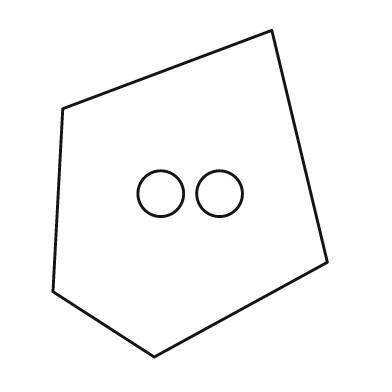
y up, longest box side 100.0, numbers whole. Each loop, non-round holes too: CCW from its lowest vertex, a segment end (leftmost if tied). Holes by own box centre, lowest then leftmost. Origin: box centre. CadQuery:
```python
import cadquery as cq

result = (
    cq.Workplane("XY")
    .moveTo(-11.0, -50.0)
    .lineTo(42.0, -21.0)
    .lineTo(25.0, 50.0)
    .lineTo(-39.0, 26.0)
    .lineTo(-42.0, -30.0)
    .close()
    .moveTo(-9.0, 0.0)
    .circle(7.0)
    .moveTo(9.0, 0.0)
    .circle(7.0)
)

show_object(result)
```